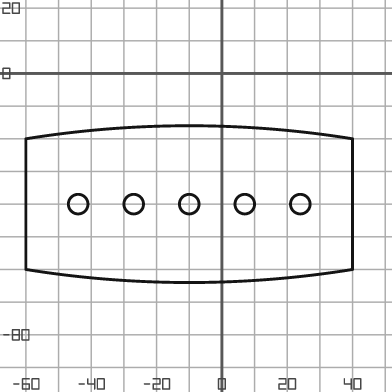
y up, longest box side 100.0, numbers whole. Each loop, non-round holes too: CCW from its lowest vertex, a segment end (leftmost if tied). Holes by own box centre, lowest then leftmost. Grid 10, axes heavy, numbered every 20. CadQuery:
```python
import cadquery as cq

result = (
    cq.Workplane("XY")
    .moveTo(-60.0, -60.0)
    .threePointArc((-10.0, -64.0), (40.0, -60.0))
    .lineTo(40.0, -20.0)
    .threePointArc((-10.0, -16.0), (-60.0, -20.0))
    .close()
    .moveTo(-44.0, -40.0)
    .circle(3.0)
    .moveTo(-27.0, -40.0)
    .circle(3.0)
    .moveTo(-10.0, -40.0)
    .circle(3.0)
    .moveTo(7.0, -40.0)
    .circle(3.0)
    .moveTo(24.0, -40.0)
    .circle(3.0)
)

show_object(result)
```